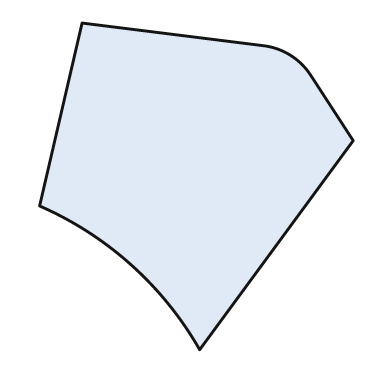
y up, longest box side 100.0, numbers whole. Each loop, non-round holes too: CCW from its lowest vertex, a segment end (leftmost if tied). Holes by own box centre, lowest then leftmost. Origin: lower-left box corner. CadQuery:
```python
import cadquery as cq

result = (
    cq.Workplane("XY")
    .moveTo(49.0, 0.0)
    .lineTo(96.0, 64.0)
    .lineTo(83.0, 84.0)
    .threePointArc((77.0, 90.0), (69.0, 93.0))
    .lineTo(13.0, 100.0)
    .lineTo(0.0, 44.0)
    .threePointArc((28.0, 26.0), (49.0, 0.0))
    .close()
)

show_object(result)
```